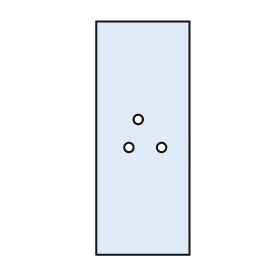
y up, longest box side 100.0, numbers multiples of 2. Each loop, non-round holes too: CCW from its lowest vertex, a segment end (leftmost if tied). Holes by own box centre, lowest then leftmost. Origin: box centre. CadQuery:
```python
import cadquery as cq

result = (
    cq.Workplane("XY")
    .moveTo(-20.0, -50.0)
    .lineTo(20.0, -50.0)
    .lineTo(20.0, 50.0)
    .lineTo(-20.0, 50.0)
    .close()
    .moveTo(-6.0, -4.0)
    .circle(2.0)
    .moveTo(8.0, -4.0)
    .circle(2.0)
    .moveTo(-2.0, 8.0)
    .circle(2.0)
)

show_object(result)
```